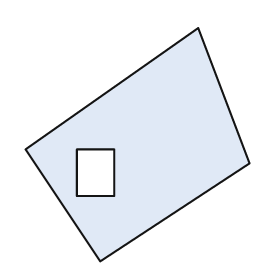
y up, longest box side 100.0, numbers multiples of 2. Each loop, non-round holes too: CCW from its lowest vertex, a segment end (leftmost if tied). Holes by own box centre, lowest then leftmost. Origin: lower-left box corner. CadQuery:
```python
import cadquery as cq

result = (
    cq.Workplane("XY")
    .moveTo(32.0, 0.0)
    .lineTo(96.0, 42.0)
    .lineTo(74.0, 100.0)
    .lineTo(0.0, 48.0)
    .close()
    .moveTo(22.0, 28.0)
    .lineTo(38.0, 28.0)
    .lineTo(38.0, 48.0)
    .lineTo(22.0, 48.0)
    .close()
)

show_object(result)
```